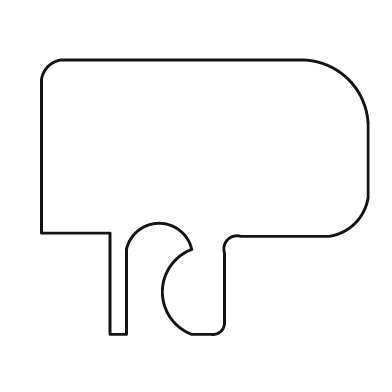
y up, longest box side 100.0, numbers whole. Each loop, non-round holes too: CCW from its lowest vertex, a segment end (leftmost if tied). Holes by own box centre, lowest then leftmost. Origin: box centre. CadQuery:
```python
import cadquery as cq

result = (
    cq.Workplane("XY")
    .moveTo(-29.0, -42.0)
    .lineTo(-24.0, -42.0)
    .lineTo(-24.0, -16.0)
    .threePointArc((-14.0, -8.0), (-4.0, -16.0))
    .threePointArc((-13.0, -29.0), (-4.0, -42.0))
    .lineTo(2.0, -42.0)
    .threePointArc((5.0, -41.0), (6.0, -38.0))
    .lineTo(6.0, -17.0)
    .threePointArc((7.0, -13.0), (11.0, -12.0))
    .lineTo(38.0, -12.0)
    .threePointArc((46.0, -8.0), (50.0, 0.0))
    .lineTo(50.0, 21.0)
    .threePointArc((44.0, 36.0), (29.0, 42.0))
    .lineTo(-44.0, 42.0)
    .threePointArc((-48.0, 40.0), (-50.0, 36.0))
    .lineTo(-50.0, -11.0)
    .lineTo(-29.0, -11.0)
    .close()
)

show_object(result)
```